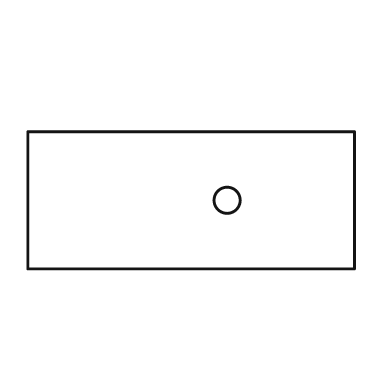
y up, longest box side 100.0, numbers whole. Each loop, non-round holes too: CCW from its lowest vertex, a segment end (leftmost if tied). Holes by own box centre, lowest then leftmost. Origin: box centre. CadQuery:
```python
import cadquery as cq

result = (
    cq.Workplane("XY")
    .moveTo(-50.0, -21.0)
    .lineTo(50.0, -21.0)
    .lineTo(50.0, 21.0)
    .lineTo(-50.0, 21.0)
    .close()
    .moveTo(11.0, 0.0)
    .circle(4.0)
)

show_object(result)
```